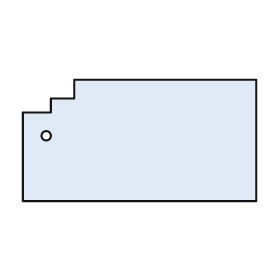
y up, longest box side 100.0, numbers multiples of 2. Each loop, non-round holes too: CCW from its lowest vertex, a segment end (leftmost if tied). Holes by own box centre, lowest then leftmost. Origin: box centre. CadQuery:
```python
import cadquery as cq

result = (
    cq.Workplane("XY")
    .moveTo(-50.0, -26.0)
    .lineTo(50.0, -26.0)
    .lineTo(50.0, 26.0)
    .lineTo(-28.0, 26.0)
    .lineTo(-28.0, 18.0)
    .lineTo(-38.0, 18.0)
    .lineTo(-38.0, 12.0)
    .lineTo(-50.0, 12.0)
    .close()
    .moveTo(-40.0, 2.0)
    .circle(2.0)
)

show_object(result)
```